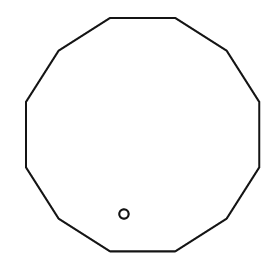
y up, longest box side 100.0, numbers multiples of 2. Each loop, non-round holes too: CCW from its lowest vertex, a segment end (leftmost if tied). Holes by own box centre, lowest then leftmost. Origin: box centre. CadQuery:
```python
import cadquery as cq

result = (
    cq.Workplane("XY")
    .moveTo(-14.0, -50.0)
    .lineTo(14.0, -50.0)
    .lineTo(36.0, -36.0)
    .lineTo(50.0, -14.0)
    .lineTo(50.0, 14.0)
    .lineTo(36.0, 36.0)
    .lineTo(14.0, 50.0)
    .lineTo(-14.0, 50.0)
    .lineTo(-36.0, 36.0)
    .lineTo(-50.0, 14.0)
    .lineTo(-50.0, -14.0)
    .lineTo(-36.0, -36.0)
    .close()
    .moveTo(-8.0, -34.0)
    .circle(2.0)
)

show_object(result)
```